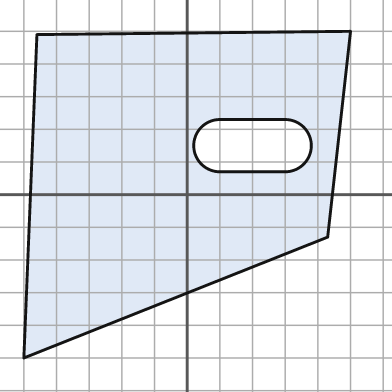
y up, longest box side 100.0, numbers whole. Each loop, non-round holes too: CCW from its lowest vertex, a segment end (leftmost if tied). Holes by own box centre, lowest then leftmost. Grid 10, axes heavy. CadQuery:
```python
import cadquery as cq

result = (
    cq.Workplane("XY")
    .moveTo(-50.0, -50.0)
    .lineTo(43.0, -13.0)
    .lineTo(50.0, 50.0)
    .lineTo(-46.0, 49.0)
    .close()
    .moveTo(10.0, 7.0)
    .lineTo(30.0, 7.0)
    .threePointArc((38.0, 15.0), (30.0, 23.0))
    .lineTo(10.0, 23.0)
    .threePointArc((2.0, 15.0), (10.0, 7.0))
    .close()
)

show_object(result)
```